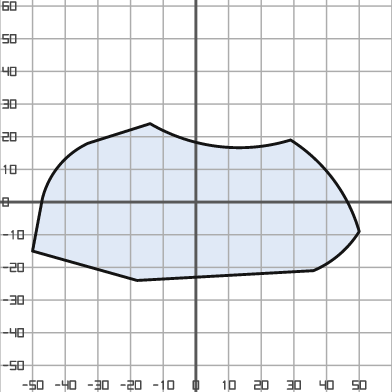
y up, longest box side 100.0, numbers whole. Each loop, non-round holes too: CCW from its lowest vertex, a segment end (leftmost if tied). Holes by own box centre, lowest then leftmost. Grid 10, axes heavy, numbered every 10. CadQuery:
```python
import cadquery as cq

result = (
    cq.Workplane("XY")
    .moveTo(-18.0, -24.0)
    .lineTo(36.0, -21.0)
    .threePointArc((44.0, -16.0), (50.0, -9.0))
    .threePointArc((42.0, 7.0), (29.0, 19.0))
    .threePointArc((7.0, 17.0), (-14.0, 24.0))
    .lineTo(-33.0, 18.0)
    .threePointArc((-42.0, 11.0), (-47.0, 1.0))
    .lineTo(-50.0, -15.0)
    .close()
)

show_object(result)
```